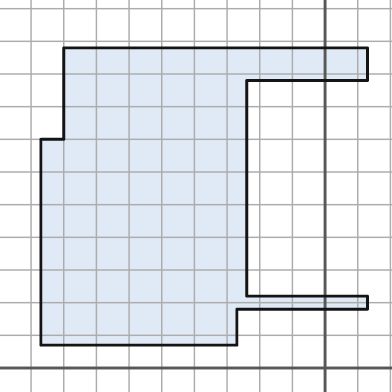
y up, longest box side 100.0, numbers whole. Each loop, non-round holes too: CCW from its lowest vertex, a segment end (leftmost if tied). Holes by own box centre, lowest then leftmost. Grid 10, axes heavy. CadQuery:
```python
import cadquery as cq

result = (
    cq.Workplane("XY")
    .moveTo(-87.0, 7.0)
    .lineTo(-27.0, 7.0)
    .lineTo(-27.0, 18.0)
    .lineTo(13.0, 18.0)
    .lineTo(13.0, 22.0)
    .lineTo(-24.0, 22.0)
    .lineTo(-24.0, 88.0)
    .lineTo(13.0, 88.0)
    .lineTo(13.0, 98.0)
    .lineTo(-80.0, 98.0)
    .lineTo(-80.0, 70.0)
    .lineTo(-87.0, 70.0)
    .close()
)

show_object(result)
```